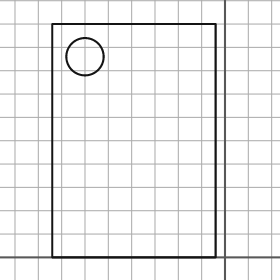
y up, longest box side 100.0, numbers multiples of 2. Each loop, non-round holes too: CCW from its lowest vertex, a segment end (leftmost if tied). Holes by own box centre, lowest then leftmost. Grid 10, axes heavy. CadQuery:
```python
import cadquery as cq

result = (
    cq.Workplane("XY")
    .moveTo(-74.0, 0.0)
    .lineTo(-4.0, 0.0)
    .lineTo(-4.0, 100.0)
    .lineTo(-74.0, 100.0)
    .close()
    .moveTo(-60.0, 86.0)
    .circle(8.0)
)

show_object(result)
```